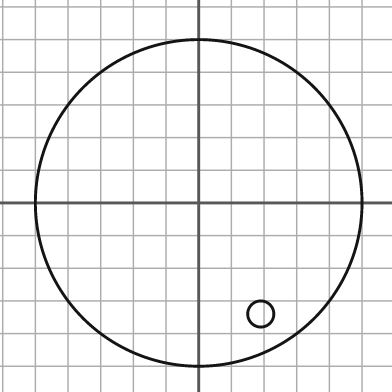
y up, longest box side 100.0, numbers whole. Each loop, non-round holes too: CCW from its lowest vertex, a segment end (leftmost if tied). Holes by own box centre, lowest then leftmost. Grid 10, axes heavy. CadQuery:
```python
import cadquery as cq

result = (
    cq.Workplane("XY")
    .moveTo(0.0, 0.0)
    .circle(50.0)
    .moveTo(19.0, -34.0)
    .circle(4.0)
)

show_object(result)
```